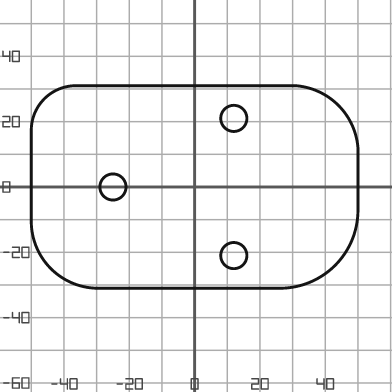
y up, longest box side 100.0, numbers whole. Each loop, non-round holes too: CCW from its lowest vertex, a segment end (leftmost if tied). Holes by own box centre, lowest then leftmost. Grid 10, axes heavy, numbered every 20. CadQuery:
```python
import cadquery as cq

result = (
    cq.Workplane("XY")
    .moveTo(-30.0, -31.0)
    .lineTo(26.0, -31.0)
    .threePointArc((43.0, -24.0), (50.0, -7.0))
    .lineTo(50.0, 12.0)
    .threePointArc((44.0, 25.0), (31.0, 31.0))
    .lineTo(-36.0, 31.0)
    .threePointArc((-46.0, 27.0), (-50.0, 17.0))
    .lineTo(-50.0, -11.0)
    .threePointArc((-44.0, -25.0), (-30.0, -31.0))
    .close()
    .moveTo(12.0, -21.0)
    .circle(4.0)
    .moveTo(-25.0, 0.0)
    .circle(4.0)
    .moveTo(12.0, 21.0)
    .circle(4.0)
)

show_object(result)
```